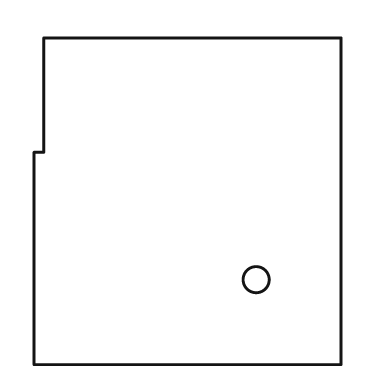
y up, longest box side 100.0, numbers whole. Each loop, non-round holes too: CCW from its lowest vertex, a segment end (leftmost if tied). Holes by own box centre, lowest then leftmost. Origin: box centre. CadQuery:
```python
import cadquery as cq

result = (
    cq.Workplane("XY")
    .moveTo(-47.0, -50.0)
    .lineTo(47.0, -50.0)
    .lineTo(47.0, 50.0)
    .lineTo(-44.0, 50.0)
    .lineTo(-44.0, 15.0)
    .lineTo(-47.0, 15.0)
    .close()
    .moveTo(21.0, -24.0)
    .circle(4.0)
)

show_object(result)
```